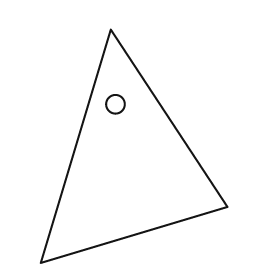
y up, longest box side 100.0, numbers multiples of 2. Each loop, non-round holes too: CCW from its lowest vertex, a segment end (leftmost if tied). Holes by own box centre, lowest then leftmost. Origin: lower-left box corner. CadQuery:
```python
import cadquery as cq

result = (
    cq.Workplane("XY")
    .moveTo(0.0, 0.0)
    .lineTo(80.0, 24.0)
    .lineTo(30.0, 100.0)
    .close()
    .moveTo(32.0, 68.0)
    .circle(4.0)
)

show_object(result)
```